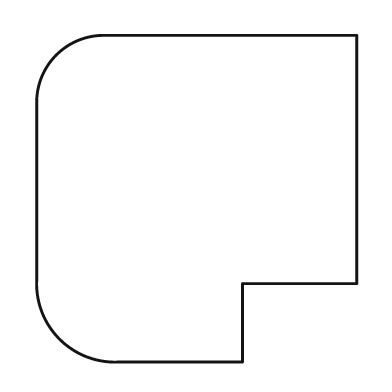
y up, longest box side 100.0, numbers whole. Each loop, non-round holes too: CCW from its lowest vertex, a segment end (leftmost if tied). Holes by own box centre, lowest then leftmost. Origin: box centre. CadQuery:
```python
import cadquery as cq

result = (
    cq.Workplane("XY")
    .moveTo(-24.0, -50.0)
    .lineTo(14.0, -50.0)
    .lineTo(14.0, -26.0)
    .lineTo(49.0, -26.0)
    .lineTo(49.0, 50.0)
    .lineTo(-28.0, 50.0)
    .threePointArc((-43.0, 44.0), (-49.0, 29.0))
    .lineTo(-49.0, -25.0)
    .threePointArc((-42.0, -43.0), (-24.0, -50.0))
    .close()
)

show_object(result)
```